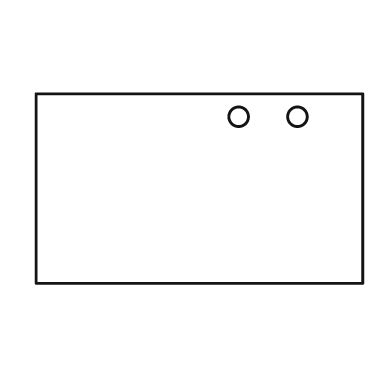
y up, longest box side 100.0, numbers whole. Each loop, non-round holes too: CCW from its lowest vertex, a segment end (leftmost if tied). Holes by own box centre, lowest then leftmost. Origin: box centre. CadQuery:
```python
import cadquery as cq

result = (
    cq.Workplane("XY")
    .moveTo(-50.0, -29.0)
    .lineTo(50.0, -29.0)
    .lineTo(50.0, 29.0)
    .lineTo(-50.0, 29.0)
    .close()
    .moveTo(12.0, 22.0)
    .circle(3.0)
    .moveTo(30.0, 22.0)
    .circle(3.0)
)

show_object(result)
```